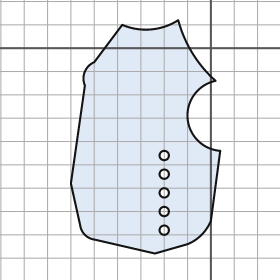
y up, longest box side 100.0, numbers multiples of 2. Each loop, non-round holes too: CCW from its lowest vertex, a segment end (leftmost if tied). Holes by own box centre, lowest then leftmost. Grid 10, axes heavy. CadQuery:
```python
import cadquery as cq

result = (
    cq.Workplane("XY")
    .moveTo(-24.0, -88.0)
    .lineTo(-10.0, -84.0)
    .threePointArc((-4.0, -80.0), (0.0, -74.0))
    .lineTo(4.0, -44.0)
    .threePointArc((-10.0, -30.0), (2.0, -14.0))
    .threePointArc((-8.0, -2.0), (-14.0, 12.0))
    .threePointArc((-26.0, 8.0), (-38.0, 10.0))
    .lineTo(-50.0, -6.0)
    .threePointArc((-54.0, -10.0), (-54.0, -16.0))
    .lineTo(-60.0, -58.0)
    .lineTo(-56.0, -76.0)
    .threePointArc((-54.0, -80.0), (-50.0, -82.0))
    .close()
    .moveTo(-20.0, -78.0)
    .circle(2.0)
    .moveTo(-20.0, -70.0)
    .circle(2.0)
    .moveTo(-20.0, -62.0)
    .circle(2.0)
    .moveTo(-20.0, -54.0)
    .circle(2.0)
    .moveTo(-20.0, -46.0)
    .circle(2.0)
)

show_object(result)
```